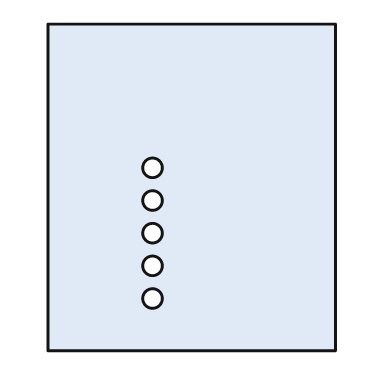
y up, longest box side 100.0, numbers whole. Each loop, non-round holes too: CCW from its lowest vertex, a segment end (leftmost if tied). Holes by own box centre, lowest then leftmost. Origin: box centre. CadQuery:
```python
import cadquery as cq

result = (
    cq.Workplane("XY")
    .moveTo(-44.0, -50.0)
    .lineTo(44.0, -50.0)
    .lineTo(44.0, 50.0)
    .lineTo(-44.0, 50.0)
    .close()
    .moveTo(-12.0, -34.0)
    .circle(3.0)
    .moveTo(-12.0, -24.0)
    .circle(3.0)
    .moveTo(-12.0, -14.0)
    .circle(3.0)
    .moveTo(-12.0, -4.0)
    .circle(3.0)
    .moveTo(-12.0, 6.0)
    .circle(3.0)
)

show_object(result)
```